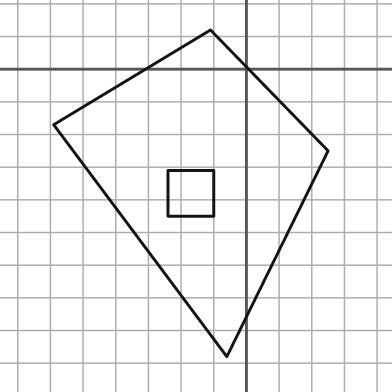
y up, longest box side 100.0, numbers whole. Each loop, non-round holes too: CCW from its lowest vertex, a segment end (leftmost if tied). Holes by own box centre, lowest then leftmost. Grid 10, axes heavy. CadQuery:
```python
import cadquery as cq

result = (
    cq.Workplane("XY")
    .moveTo(-6.0, -88.0)
    .lineTo(25.0, -25.0)
    .lineTo(-11.0, 12.0)
    .lineTo(-59.0, -17.0)
    .close()
    .moveTo(-24.0, -45.0)
    .lineTo(-10.0, -45.0)
    .lineTo(-10.0, -31.0)
    .lineTo(-24.0, -31.0)
    .close()
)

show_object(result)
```